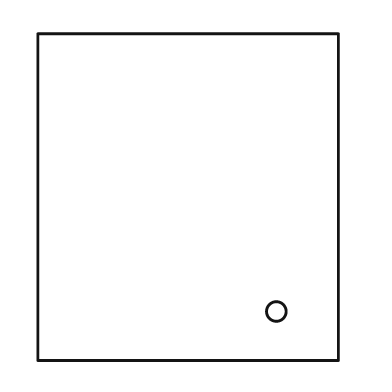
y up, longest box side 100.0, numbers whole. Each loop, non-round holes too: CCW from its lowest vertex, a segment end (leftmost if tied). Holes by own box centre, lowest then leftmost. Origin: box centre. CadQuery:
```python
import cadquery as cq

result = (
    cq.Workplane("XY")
    .moveTo(-46.0, -50.0)
    .lineTo(46.0, -50.0)
    .lineTo(46.0, 50.0)
    .lineTo(-46.0, 50.0)
    .close()
    .moveTo(27.0, -35.0)
    .circle(3.0)
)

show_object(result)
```